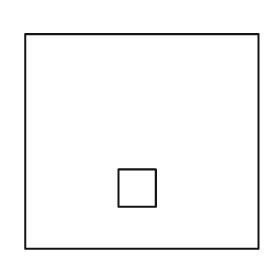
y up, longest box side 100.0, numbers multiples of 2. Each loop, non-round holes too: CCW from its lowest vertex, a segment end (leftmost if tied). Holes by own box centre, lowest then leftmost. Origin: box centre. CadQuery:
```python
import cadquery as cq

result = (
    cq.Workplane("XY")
    .moveTo(-50.0, -46.0)
    .lineTo(50.0, -46.0)
    .lineTo(50.0, 46.0)
    .lineTo(-50.0, 46.0)
    .close()
    .moveTo(-10.0, -28.0)
    .lineTo(6.0, -28.0)
    .lineTo(6.0, -12.0)
    .lineTo(-10.0, -12.0)
    .close()
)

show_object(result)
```